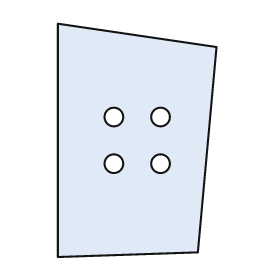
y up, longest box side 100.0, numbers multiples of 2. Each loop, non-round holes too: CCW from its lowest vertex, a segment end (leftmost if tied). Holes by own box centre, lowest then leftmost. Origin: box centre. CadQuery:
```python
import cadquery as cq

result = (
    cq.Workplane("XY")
    .moveTo(-34.0, -50.0)
    .lineTo(26.0, -48.0)
    .lineTo(34.0, 40.0)
    .lineTo(-34.0, 50.0)
    .close()
    .moveTo(-10.0, -10.0)
    .circle(4.0)
    .moveTo(10.0, -10.0)
    .circle(4.0)
    .moveTo(-10.0, 10.0)
    .circle(4.0)
    .moveTo(10.0, 10.0)
    .circle(4.0)
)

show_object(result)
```